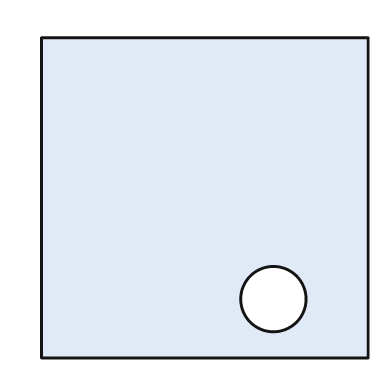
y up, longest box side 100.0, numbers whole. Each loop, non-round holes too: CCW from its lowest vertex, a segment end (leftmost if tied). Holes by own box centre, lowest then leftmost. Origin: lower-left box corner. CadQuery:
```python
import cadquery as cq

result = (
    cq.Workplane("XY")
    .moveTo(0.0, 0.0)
    .lineTo(100.0, 0.0)
    .lineTo(100.0, 98.0)
    .lineTo(0.0, 98.0)
    .close()
    .moveTo(71.0, 18.0)
    .circle(10.0)
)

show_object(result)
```